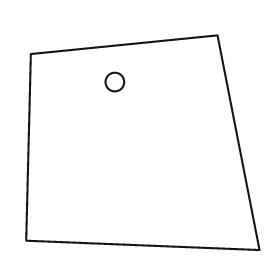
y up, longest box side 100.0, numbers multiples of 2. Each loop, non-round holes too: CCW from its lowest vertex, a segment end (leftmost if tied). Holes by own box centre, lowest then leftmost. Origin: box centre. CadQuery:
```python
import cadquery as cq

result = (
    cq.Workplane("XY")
    .moveTo(50.0, -46.0)
    .lineTo(32.0, 46.0)
    .lineTo(-48.0, 38.0)
    .lineTo(-50.0, -42.0)
    .close()
    .moveTo(-12.0, 26.0)
    .circle(4.0)
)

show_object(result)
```